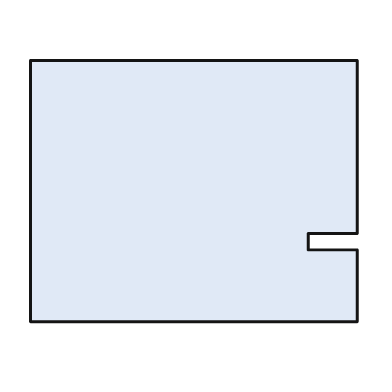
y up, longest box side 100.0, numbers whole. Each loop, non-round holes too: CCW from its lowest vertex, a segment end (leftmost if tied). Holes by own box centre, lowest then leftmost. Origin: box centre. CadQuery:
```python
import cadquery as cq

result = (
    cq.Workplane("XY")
    .moveTo(-50.0, -40.0)
    .lineTo(50.0, -40.0)
    .lineTo(50.0, -18.0)
    .lineTo(35.0, -18.0)
    .lineTo(35.0, -13.0)
    .lineTo(50.0, -13.0)
    .lineTo(50.0, 40.0)
    .lineTo(-50.0, 40.0)
    .close()
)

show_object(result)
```